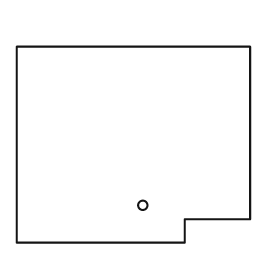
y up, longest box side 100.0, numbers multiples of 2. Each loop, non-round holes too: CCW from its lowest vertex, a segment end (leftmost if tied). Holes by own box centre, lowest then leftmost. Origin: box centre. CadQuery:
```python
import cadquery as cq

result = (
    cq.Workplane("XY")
    .moveTo(-50.0, -42.0)
    .lineTo(22.0, -42.0)
    .lineTo(22.0, -32.0)
    .lineTo(50.0, -32.0)
    .lineTo(50.0, 42.0)
    .lineTo(-50.0, 42.0)
    .close()
    .moveTo(4.0, -26.0)
    .circle(2.0)
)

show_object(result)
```